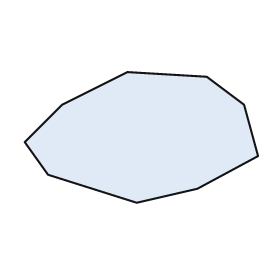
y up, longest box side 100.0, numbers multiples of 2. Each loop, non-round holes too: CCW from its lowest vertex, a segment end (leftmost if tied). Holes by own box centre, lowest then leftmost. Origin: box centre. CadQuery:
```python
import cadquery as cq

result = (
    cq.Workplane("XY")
    .moveTo(-2.0, -28.0)
    .lineTo(24.0, -22.0)
    .lineTo(50.0, -8.0)
    .lineTo(44.0, 14.0)
    .lineTo(28.0, 26.0)
    .lineTo(-6.0, 28.0)
    .lineTo(-34.0, 14.0)
    .lineTo(-50.0, -2.0)
    .lineTo(-40.0, -16.0)
    .close()
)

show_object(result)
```